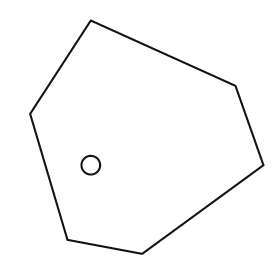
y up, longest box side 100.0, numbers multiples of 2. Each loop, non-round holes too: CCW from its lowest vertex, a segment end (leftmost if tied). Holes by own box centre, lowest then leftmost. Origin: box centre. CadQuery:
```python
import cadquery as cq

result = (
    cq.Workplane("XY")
    .moveTo(-2.0, -50.0)
    .lineTo(50.0, -12.0)
    .lineTo(38.0, 22.0)
    .lineTo(-24.0, 50.0)
    .lineTo(-50.0, 10.0)
    .lineTo(-34.0, -44.0)
    .close()
    .moveTo(-24.0, -12.0)
    .circle(4.0)
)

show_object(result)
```